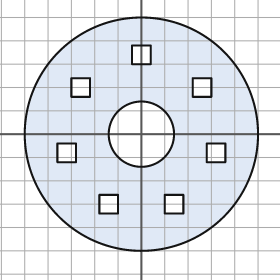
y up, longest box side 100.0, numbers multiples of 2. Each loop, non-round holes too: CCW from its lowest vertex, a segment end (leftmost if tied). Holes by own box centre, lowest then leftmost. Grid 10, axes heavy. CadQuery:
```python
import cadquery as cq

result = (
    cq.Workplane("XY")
    .moveTo(0.0, 0.0)
    .circle(50.0)
    .moveTo(-18.0, -34.0)
    .lineTo(-10.0, -34.0)
    .lineTo(-10.0, -26.0)
    .lineTo(-18.0, -26.0)
    .close()
    .moveTo(10.0, -34.0)
    .lineTo(18.0, -34.0)
    .lineTo(18.0, -26.0)
    .lineTo(10.0, -26.0)
    .close()
    .moveTo(-36.0, -12.0)
    .lineTo(-28.0, -12.0)
    .lineTo(-28.0, -4.0)
    .lineTo(-36.0, -4.0)
    .close()
    .moveTo(28.0, -12.0)
    .lineTo(36.0, -12.0)
    .lineTo(36.0, -4.0)
    .lineTo(28.0, -4.0)
    .close()
    .moveTo(0.0, 0.0)
    .circle(14.0)
    .moveTo(-30.0, 16.0)
    .lineTo(-22.0, 16.0)
    .lineTo(-22.0, 24.0)
    .lineTo(-30.0, 24.0)
    .close()
    .moveTo(22.0, 16.0)
    .lineTo(30.0, 16.0)
    .lineTo(30.0, 24.0)
    .lineTo(22.0, 24.0)
    .close()
    .moveTo(-4.0, 30.0)
    .lineTo(4.0, 30.0)
    .lineTo(4.0, 38.0)
    .lineTo(-4.0, 38.0)
    .close()
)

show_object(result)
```